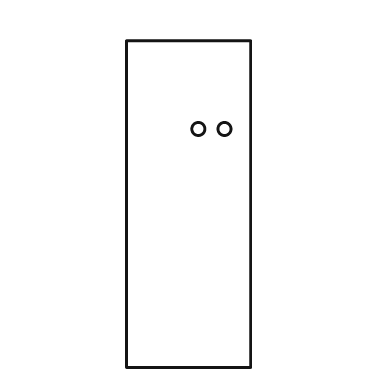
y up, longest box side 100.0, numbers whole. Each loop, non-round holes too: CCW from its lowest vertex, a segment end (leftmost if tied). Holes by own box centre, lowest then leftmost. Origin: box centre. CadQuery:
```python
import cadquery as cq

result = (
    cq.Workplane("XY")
    .moveTo(-19.0, -50.0)
    .lineTo(19.0, -50.0)
    .lineTo(19.0, 50.0)
    .lineTo(-19.0, 50.0)
    .close()
    .moveTo(3.0, 23.0)
    .circle(2.0)
    .moveTo(11.0, 23.0)
    .circle(2.0)
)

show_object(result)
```